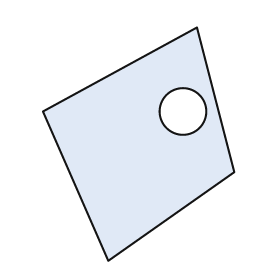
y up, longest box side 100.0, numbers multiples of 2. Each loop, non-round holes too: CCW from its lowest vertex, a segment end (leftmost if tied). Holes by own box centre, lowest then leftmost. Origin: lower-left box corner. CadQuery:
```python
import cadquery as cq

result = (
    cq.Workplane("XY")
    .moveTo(28.0, 0.0)
    .lineTo(82.0, 38.0)
    .lineTo(66.0, 100.0)
    .lineTo(0.0, 64.0)
    .close()
    .moveTo(60.0, 64.0)
    .circle(10.0)
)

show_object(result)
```